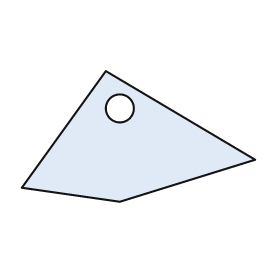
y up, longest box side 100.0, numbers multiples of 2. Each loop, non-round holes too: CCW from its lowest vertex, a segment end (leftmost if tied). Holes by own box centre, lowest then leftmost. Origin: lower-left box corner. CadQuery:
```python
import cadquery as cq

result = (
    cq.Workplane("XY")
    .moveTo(42.0, 0.0)
    .lineTo(100.0, 18.0)
    .lineTo(36.0, 56.0)
    .lineTo(0.0, 6.0)
    .close()
    .moveTo(42.0, 40.0)
    .circle(6.0)
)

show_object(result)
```